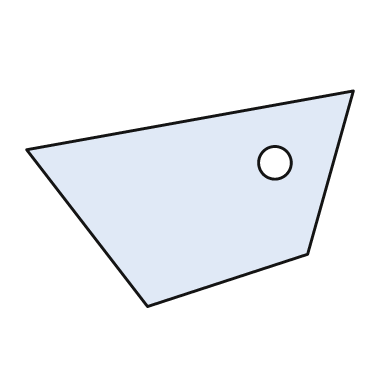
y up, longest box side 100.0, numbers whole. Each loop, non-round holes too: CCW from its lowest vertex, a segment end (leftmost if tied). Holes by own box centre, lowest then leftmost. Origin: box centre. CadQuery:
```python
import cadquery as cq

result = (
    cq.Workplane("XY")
    .moveTo(-13.0, -33.0)
    .lineTo(36.0, -17.0)
    .lineTo(50.0, 33.0)
    .lineTo(-50.0, 15.0)
    .close()
    .moveTo(26.0, 11.0)
    .circle(5.0)
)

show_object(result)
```